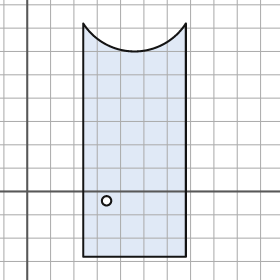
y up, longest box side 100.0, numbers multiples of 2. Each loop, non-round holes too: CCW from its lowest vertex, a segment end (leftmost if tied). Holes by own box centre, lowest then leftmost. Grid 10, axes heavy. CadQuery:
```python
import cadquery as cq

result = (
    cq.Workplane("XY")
    .moveTo(24.0, -28.0)
    .lineTo(68.0, -28.0)
    .lineTo(68.0, 72.0)
    .threePointArc((46.0, 60.0), (24.0, 72.0))
    .close()
    .moveTo(34.0, -4.0)
    .circle(2.0)
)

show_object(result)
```